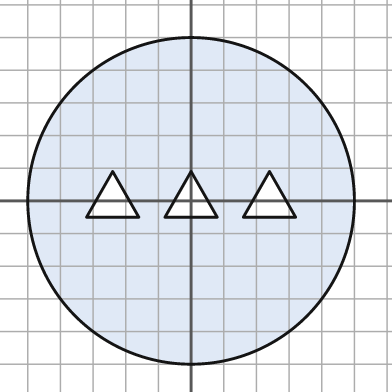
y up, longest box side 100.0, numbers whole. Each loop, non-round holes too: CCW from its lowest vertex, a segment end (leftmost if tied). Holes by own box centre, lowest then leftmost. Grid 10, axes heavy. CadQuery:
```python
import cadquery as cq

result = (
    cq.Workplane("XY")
    .moveTo(0.0, 0.0)
    .circle(50.0)
    .moveTo(-32.0, -5.0)
    .lineTo(-16.0, -5.0)
    .lineTo(-24.0, 9.0)
    .close()
    .moveTo(-8.0, -5.0)
    .lineTo(8.0, -5.0)
    .lineTo(0.0, 9.0)
    .close()
    .moveTo(16.0, -5.0)
    .lineTo(32.0, -5.0)
    .lineTo(24.0, 9.0)
    .close()
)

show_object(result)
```